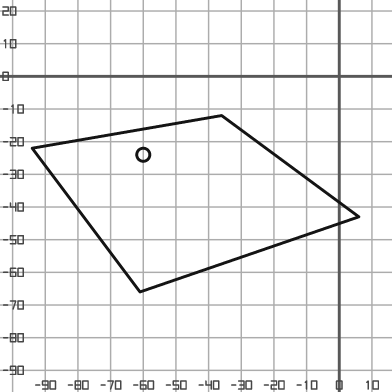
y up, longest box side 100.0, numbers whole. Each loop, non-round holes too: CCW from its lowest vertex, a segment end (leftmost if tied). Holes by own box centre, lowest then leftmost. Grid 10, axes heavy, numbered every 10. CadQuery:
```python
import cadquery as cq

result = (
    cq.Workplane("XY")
    .moveTo(-61.0, -66.0)
    .lineTo(6.0, -43.0)
    .lineTo(-36.0, -12.0)
    .lineTo(-94.0, -22.0)
    .close()
    .moveTo(-60.0, -24.0)
    .circle(2.0)
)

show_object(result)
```